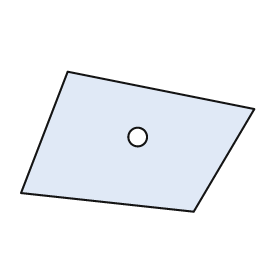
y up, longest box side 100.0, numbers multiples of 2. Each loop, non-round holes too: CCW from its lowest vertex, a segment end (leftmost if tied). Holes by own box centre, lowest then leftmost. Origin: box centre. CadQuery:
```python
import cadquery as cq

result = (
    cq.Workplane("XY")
    .moveTo(24.0, -30.0)
    .lineTo(50.0, 14.0)
    .lineTo(-30.0, 30.0)
    .lineTo(-50.0, -22.0)
    .close()
    .moveTo(0.0, 2.0)
    .circle(4.0)
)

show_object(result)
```